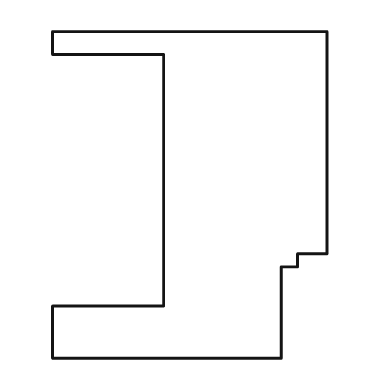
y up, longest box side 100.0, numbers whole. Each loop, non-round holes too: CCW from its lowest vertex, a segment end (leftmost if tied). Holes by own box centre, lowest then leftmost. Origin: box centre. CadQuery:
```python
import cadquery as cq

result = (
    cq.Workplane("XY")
    .moveTo(-42.0, -50.0)
    .lineTo(28.0, -50.0)
    .lineTo(28.0, -22.0)
    .lineTo(33.0, -22.0)
    .lineTo(33.0, -18.0)
    .lineTo(42.0, -18.0)
    .lineTo(42.0, 50.0)
    .lineTo(-42.0, 50.0)
    .lineTo(-42.0, 43.0)
    .lineTo(-8.0, 43.0)
    .lineTo(-8.0, -34.0)
    .lineTo(-42.0, -34.0)
    .close()
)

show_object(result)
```